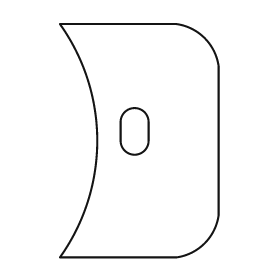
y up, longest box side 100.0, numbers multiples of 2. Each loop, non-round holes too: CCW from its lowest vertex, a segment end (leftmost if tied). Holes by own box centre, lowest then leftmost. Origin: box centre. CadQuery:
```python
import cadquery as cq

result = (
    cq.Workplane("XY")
    .moveTo(-34.0, -50.0)
    .lineTo(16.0, -50.0)
    .threePointArc((28.0, -44.0), (34.0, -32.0))
    .lineTo(34.0, 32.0)
    .threePointArc((28.0, 44.0), (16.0, 50.0))
    .lineTo(-34.0, 50.0)
    .threePointArc((-18.0, 0.0), (-34.0, -50.0))
    .close()
    .moveTo(-8.0, 0.0)
    .threePointArc((-2.0, -6.0), (4.0, 0.0))
    .lineTo(4.0, 8.0)
    .threePointArc((-2.0, 14.0), (-8.0, 8.0))
    .close()
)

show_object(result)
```